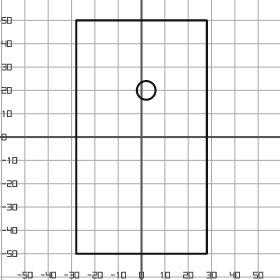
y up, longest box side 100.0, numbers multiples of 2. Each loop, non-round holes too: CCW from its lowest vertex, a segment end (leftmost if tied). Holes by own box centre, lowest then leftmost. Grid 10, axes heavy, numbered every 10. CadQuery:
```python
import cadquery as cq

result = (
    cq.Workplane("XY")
    .moveTo(-28.0, -50.0)
    .lineTo(28.0, -50.0)
    .lineTo(28.0, 50.0)
    .lineTo(-28.0, 50.0)
    .close()
    .moveTo(2.0, 20.0)
    .circle(4.0)
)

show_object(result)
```